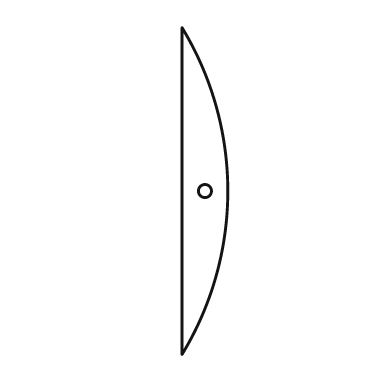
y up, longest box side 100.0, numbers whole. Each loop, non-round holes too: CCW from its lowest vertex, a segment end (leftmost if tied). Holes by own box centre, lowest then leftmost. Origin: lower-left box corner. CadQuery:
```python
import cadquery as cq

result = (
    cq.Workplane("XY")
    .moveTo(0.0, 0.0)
    .threePointArc((14.0, 50.0), (0.0, 100.0))
    .close()
    .moveTo(7.0, 50.0)
    .circle(2.0)
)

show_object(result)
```